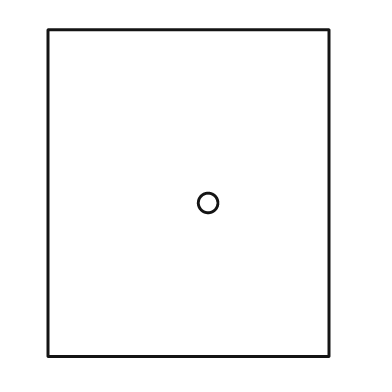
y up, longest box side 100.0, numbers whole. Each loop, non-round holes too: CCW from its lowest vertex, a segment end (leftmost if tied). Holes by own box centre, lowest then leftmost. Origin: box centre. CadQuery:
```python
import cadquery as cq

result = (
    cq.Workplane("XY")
    .moveTo(-43.0, -50.0)
    .lineTo(43.0, -50.0)
    .lineTo(43.0, 50.0)
    .lineTo(-43.0, 50.0)
    .close()
    .moveTo(6.0, -3.0)
    .circle(3.0)
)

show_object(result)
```